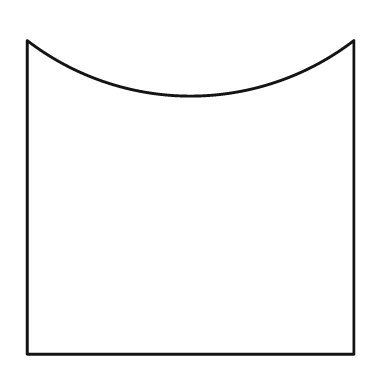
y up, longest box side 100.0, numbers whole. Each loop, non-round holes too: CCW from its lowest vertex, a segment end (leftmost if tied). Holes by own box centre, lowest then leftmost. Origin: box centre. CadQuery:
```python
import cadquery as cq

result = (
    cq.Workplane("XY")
    .moveTo(-50.0, -48.0)
    .lineTo(50.0, -48.0)
    .lineTo(50.0, 48.0)
    .threePointArc((0.0, 31.0), (-50.0, 48.0))
    .close()
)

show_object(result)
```